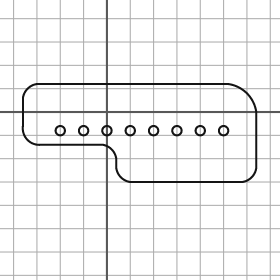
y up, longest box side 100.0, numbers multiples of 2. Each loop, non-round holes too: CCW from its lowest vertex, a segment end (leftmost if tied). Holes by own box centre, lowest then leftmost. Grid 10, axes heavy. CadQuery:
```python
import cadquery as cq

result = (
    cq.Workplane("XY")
    .moveTo(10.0, -30.0)
    .lineTo(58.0, -30.0)
    .threePointArc((62.0, -28.0), (64.0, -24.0))
    .lineTo(64.0, 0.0)
    .threePointArc((60.0, 8.0), (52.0, 12.0))
    .lineTo(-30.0, 12.0)
    .threePointArc((-34.0, 10.0), (-36.0, 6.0))
    .lineTo(-36.0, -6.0)
    .threePointArc((-34.0, -12.0), (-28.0, -14.0))
    .lineTo(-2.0, -14.0)
    .threePointArc((2.0, -16.0), (4.0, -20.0))
    .lineTo(4.0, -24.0)
    .threePointArc((6.0, -28.0), (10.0, -30.0))
    .close()
    .moveTo(-20.0, -8.0)
    .circle(2.0)
    .moveTo(-10.0, -8.0)
    .circle(2.0)
    .moveTo(0.0, -8.0)
    .circle(2.0)
    .moveTo(10.0, -8.0)
    .circle(2.0)
    .moveTo(20.0, -8.0)
    .circle(2.0)
    .moveTo(30.0, -8.0)
    .circle(2.0)
    .moveTo(40.0, -8.0)
    .circle(2.0)
    .moveTo(50.0, -8.0)
    .circle(2.0)
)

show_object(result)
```